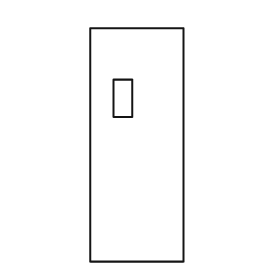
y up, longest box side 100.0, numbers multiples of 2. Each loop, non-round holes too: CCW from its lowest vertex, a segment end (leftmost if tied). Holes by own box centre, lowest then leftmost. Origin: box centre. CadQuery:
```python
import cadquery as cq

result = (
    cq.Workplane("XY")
    .moveTo(-20.0, -50.0)
    .lineTo(20.0, -50.0)
    .lineTo(20.0, 50.0)
    .lineTo(-20.0, 50.0)
    .close()
    .moveTo(-10.0, 12.0)
    .lineTo(-2.0, 12.0)
    .lineTo(-2.0, 28.0)
    .lineTo(-10.0, 28.0)
    .close()
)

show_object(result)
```